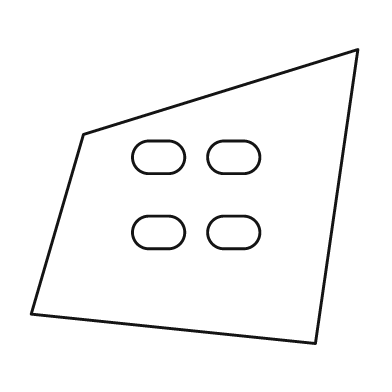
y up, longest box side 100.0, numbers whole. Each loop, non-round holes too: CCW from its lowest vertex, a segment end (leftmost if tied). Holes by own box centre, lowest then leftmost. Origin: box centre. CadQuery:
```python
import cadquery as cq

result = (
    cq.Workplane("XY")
    .moveTo(37.0, -45.0)
    .lineTo(50.0, 45.0)
    .lineTo(-34.0, 19.0)
    .lineTo(-50.0, -36.0)
    .close()
    .moveTo(-14.0, -16.0)
    .lineTo(-8.0, -16.0)
    .threePointArc((-3.0, -11.0), (-8.0, -6.0))
    .lineTo(-14.0, -6.0)
    .threePointArc((-19.0, -11.0), (-14.0, -16.0))
    .close()
    .moveTo(9.0, -16.0)
    .lineTo(15.0, -16.0)
    .threePointArc((20.0, -11.0), (15.0, -6.0))
    .lineTo(9.0, -6.0)
    .threePointArc((4.0, -11.0), (9.0, -16.0))
    .close()
    .moveTo(-14.0, 7.0)
    .lineTo(-8.0, 7.0)
    .threePointArc((-3.0, 12.0), (-8.0, 17.0))
    .lineTo(-14.0, 17.0)
    .threePointArc((-19.0, 12.0), (-14.0, 7.0))
    .close()
    .moveTo(9.0, 7.0)
    .lineTo(15.0, 7.0)
    .threePointArc((20.0, 12.0), (15.0, 17.0))
    .lineTo(9.0, 17.0)
    .threePointArc((4.0, 12.0), (9.0, 7.0))
    .close()
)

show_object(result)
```